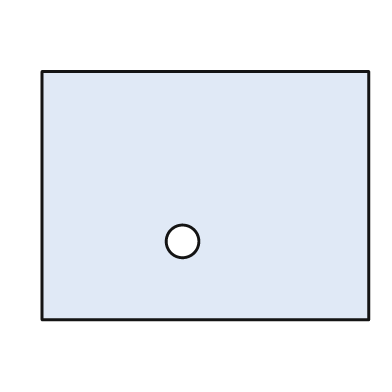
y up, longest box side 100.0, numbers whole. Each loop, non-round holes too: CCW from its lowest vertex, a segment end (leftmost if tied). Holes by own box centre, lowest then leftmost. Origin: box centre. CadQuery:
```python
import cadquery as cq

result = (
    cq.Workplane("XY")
    .moveTo(-50.0, -38.0)
    .lineTo(50.0, -38.0)
    .lineTo(50.0, 38.0)
    .lineTo(-50.0, 38.0)
    .close()
    .moveTo(-7.0, -14.0)
    .circle(5.0)
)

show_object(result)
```